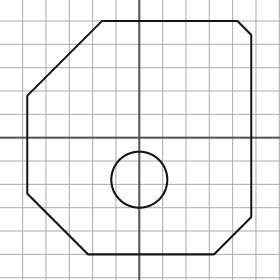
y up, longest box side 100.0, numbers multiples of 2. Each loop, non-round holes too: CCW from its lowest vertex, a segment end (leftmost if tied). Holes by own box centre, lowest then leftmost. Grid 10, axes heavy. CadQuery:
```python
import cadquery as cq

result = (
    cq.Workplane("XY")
    .moveTo(-22.0, -50.0)
    .lineTo(32.0, -50.0)
    .lineTo(48.0, -34.0)
    .lineTo(48.0, 44.0)
    .lineTo(42.0, 50.0)
    .lineTo(-16.0, 50.0)
    .lineTo(-48.0, 18.0)
    .lineTo(-48.0, -24.0)
    .close()
    .moveTo(0.0, -18.0)
    .circle(12.0)
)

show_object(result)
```